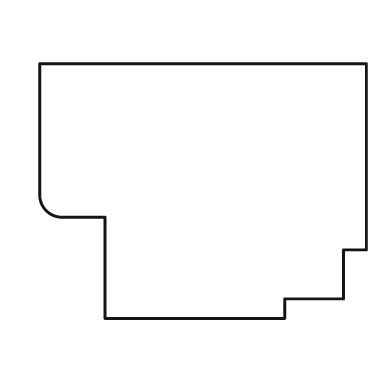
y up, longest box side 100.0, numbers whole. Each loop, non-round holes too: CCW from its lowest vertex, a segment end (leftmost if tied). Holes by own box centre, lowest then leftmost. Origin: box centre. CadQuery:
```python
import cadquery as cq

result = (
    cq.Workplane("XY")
    .moveTo(-30.0, -39.0)
    .lineTo(25.0, -39.0)
    .lineTo(25.0, -33.0)
    .lineTo(43.0, -33.0)
    .lineTo(43.0, -18.0)
    .lineTo(50.0, -18.0)
    .lineTo(50.0, 39.0)
    .lineTo(-50.0, 39.0)
    .lineTo(-50.0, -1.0)
    .threePointArc((-48.0, -6.0), (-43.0, -8.0))
    .lineTo(-30.0, -8.0)
    .close()
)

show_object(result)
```